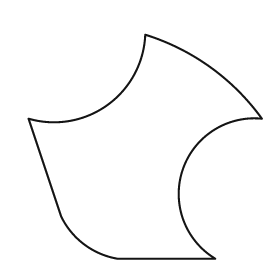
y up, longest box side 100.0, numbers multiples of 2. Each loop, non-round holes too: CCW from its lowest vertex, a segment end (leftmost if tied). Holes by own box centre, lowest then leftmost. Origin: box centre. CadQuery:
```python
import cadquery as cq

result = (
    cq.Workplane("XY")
    .moveTo(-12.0, -48.0)
    .lineTo(30.0, -48.0)
    .threePointArc((16.0, -10.0), (50.0, 12.0))
    .threePointArc((28.0, 34.0), (0.0, 48.0))
    .threePointArc((-16.0, 18.0), (-50.0, 12.0))
    .lineTo(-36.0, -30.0)
    .threePointArc((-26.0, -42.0), (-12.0, -48.0))
    .close()
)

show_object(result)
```